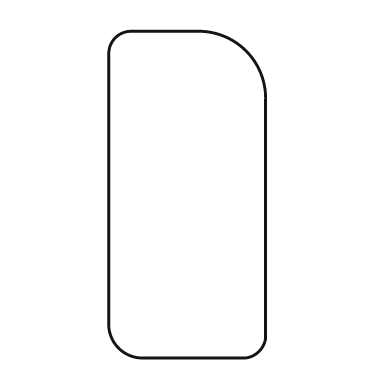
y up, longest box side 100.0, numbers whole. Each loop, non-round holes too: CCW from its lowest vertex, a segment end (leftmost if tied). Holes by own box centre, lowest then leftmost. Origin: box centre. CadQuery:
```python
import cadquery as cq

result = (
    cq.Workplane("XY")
    .moveTo(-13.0, -50.0)
    .lineTo(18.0, -50.0)
    .threePointArc((22.0, -48.0), (24.0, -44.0))
    .lineTo(24.0, 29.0)
    .threePointArc((18.0, 44.0), (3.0, 50.0))
    .lineTo(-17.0, 50.0)
    .threePointArc((-22.0, 48.0), (-24.0, 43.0))
    .lineTo(-24.0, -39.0)
    .threePointArc((-21.0, -47.0), (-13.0, -50.0))
    .close()
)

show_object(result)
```